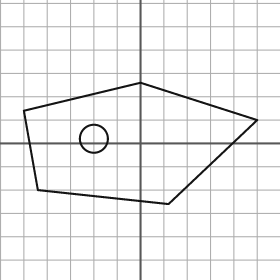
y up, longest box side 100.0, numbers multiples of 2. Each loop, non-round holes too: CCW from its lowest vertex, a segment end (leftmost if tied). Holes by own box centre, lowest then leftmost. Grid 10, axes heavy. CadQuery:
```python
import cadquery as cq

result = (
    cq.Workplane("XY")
    .moveTo(12.0, -26.0)
    .lineTo(50.0, 10.0)
    .lineTo(0.0, 26.0)
    .lineTo(-50.0, 14.0)
    .lineTo(-44.0, -20.0)
    .close()
    .moveTo(-20.0, 2.0)
    .circle(6.0)
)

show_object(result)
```